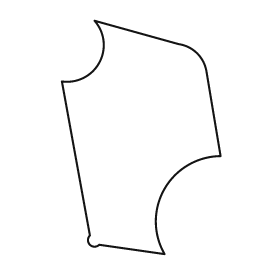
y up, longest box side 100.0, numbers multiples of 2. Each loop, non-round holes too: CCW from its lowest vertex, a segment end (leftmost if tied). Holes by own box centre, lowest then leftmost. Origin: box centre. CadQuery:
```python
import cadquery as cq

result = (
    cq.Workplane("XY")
    .moveTo(10.0, -50.0)
    .threePointArc((10.0, -22.0), (34.0, -8.0))
    .lineTo(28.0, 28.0)
    .threePointArc((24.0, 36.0), (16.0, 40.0))
    .lineTo(-20.0, 50.0)
    .threePointArc((-18.0, 32.0), (-34.0, 24.0))
    .lineTo(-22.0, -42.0)
    .threePointArc((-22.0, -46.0), (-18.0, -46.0))
    .close()
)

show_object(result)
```